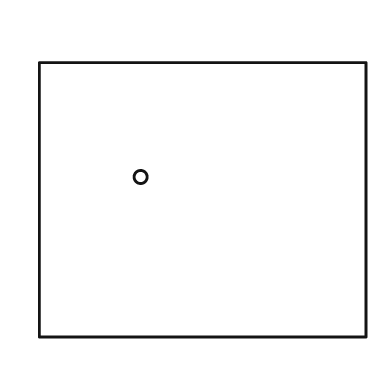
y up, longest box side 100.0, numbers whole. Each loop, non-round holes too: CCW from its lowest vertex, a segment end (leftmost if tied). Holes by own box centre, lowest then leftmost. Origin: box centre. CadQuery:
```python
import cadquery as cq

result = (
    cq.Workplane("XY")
    .moveTo(-50.0, -42.0)
    .lineTo(50.0, -42.0)
    .lineTo(50.0, 42.0)
    .lineTo(-50.0, 42.0)
    .close()
    .moveTo(-19.0, 7.0)
    .circle(2.0)
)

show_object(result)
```